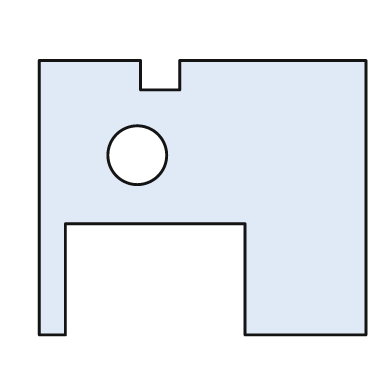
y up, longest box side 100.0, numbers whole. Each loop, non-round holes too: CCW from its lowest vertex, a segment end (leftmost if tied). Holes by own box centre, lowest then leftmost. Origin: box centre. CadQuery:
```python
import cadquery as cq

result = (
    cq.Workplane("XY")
    .moveTo(-50.0, -42.0)
    .lineTo(-42.0, -42.0)
    .lineTo(-42.0, -8.0)
    .lineTo(13.0, -8.0)
    .lineTo(13.0, -42.0)
    .lineTo(50.0, -42.0)
    .lineTo(50.0, 42.0)
    .lineTo(-7.0, 42.0)
    .lineTo(-7.0, 33.0)
    .lineTo(-19.0, 33.0)
    .lineTo(-19.0, 42.0)
    .lineTo(-50.0, 42.0)
    .close()
    .moveTo(-20.0, 13.0)
    .circle(9.0)
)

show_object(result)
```